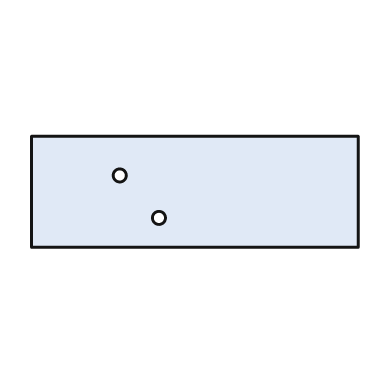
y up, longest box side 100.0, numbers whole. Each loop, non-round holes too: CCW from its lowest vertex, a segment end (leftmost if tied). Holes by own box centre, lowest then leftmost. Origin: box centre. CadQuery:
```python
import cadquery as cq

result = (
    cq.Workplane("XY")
    .moveTo(-50.0, -17.0)
    .lineTo(50.0, -17.0)
    .lineTo(50.0, 17.0)
    .lineTo(-50.0, 17.0)
    .close()
    .moveTo(-11.0, -8.0)
    .circle(2.0)
    .moveTo(-23.0, 5.0)
    .circle(2.0)
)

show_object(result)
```